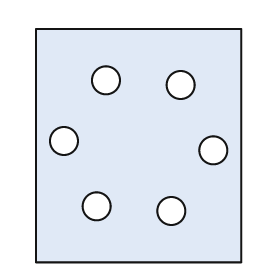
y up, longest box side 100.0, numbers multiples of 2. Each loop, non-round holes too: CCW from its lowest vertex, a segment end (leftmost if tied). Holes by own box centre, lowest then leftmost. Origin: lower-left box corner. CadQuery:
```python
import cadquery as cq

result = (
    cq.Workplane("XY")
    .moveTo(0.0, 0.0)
    .lineTo(88.0, 0.0)
    .lineTo(88.0, 100.0)
    .lineTo(0.0, 100.0)
    .close()
    .moveTo(58.0, 22.0)
    .circle(6.0)
    .moveTo(26.0, 24.0)
    .circle(6.0)
    .moveTo(76.0, 48.0)
    .circle(6.0)
    .moveTo(12.0, 52.0)
    .circle(6.0)
    .moveTo(62.0, 76.0)
    .circle(6.0)
    .moveTo(30.0, 78.0)
    .circle(6.0)
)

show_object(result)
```